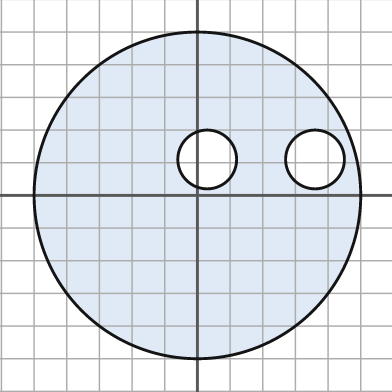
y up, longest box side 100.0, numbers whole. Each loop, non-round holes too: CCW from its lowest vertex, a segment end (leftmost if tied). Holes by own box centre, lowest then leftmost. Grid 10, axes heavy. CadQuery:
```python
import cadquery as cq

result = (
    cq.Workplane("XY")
    .moveTo(0.0, 0.0)
    .circle(50.0)
    .moveTo(3.0, 11.0)
    .circle(9.0)
    .moveTo(36.0, 11.0)
    .circle(9.0)
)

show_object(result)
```